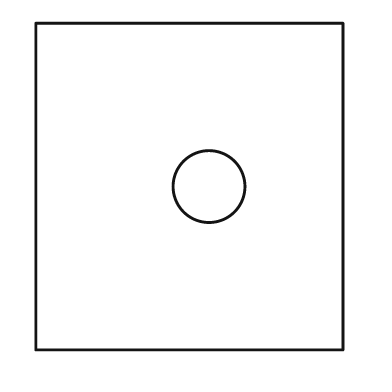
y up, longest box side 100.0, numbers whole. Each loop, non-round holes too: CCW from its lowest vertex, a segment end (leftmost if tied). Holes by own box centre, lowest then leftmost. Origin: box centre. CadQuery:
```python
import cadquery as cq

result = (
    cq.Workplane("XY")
    .moveTo(-47.0, -50.0)
    .lineTo(47.0, -50.0)
    .lineTo(47.0, 50.0)
    .lineTo(-47.0, 50.0)
    .close()
    .moveTo(6.0, 0.0)
    .circle(11.0)
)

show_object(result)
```